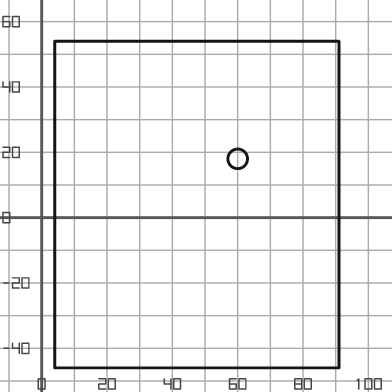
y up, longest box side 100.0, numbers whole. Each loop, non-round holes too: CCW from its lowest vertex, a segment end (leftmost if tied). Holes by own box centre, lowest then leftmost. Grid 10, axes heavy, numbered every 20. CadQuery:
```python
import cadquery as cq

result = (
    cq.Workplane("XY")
    .moveTo(4.0, -46.0)
    .lineTo(91.0, -46.0)
    .lineTo(91.0, 54.0)
    .lineTo(4.0, 54.0)
    .close()
    .moveTo(60.0, 18.0)
    .circle(3.0)
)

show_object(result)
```